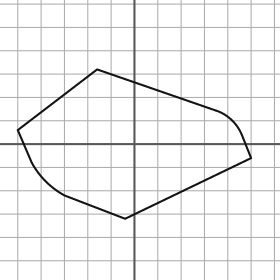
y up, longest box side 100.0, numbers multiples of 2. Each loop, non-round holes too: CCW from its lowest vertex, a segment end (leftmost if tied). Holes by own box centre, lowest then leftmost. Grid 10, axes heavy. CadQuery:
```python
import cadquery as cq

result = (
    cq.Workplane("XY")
    .moveTo(-4.0, -32.0)
    .lineTo(50.0, -6.0)
    .lineTo(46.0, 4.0)
    .threePointArc((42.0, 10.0), (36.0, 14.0))
    .lineTo(-16.0, 32.0)
    .lineTo(-50.0, 6.0)
    .lineTo(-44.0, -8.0)
    .threePointArc((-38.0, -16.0), (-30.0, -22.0))
    .close()
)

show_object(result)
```